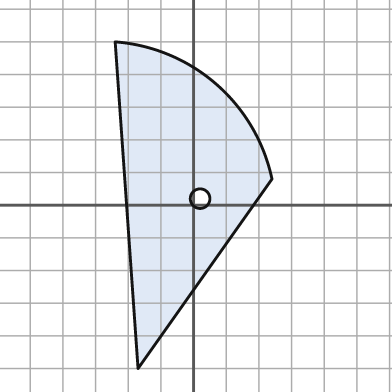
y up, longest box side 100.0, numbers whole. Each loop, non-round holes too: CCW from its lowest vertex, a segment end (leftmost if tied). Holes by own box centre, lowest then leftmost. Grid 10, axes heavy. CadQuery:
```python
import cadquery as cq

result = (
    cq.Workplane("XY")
    .moveTo(-17.0, -50.0)
    .lineTo(24.0, 8.0)
    .threePointArc((7.0, 37.0), (-24.0, 50.0))
    .close()
    .moveTo(2.0, 2.0)
    .circle(3.0)
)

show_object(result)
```